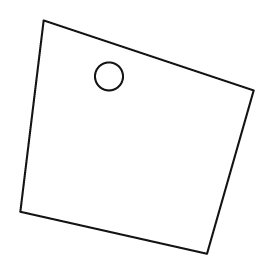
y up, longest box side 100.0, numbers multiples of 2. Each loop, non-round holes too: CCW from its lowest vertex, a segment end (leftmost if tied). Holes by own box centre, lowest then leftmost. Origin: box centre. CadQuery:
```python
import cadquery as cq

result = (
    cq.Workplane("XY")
    .moveTo(30.0, -50.0)
    .lineTo(50.0, 20.0)
    .lineTo(-40.0, 50.0)
    .lineTo(-50.0, -32.0)
    .close()
    .moveTo(-12.0, 26.0)
    .circle(6.0)
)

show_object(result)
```